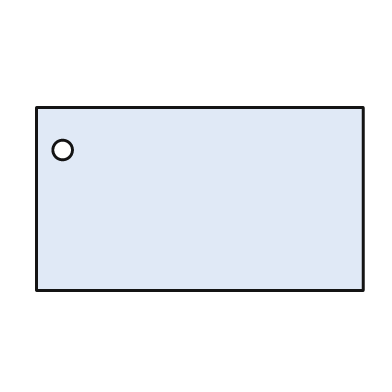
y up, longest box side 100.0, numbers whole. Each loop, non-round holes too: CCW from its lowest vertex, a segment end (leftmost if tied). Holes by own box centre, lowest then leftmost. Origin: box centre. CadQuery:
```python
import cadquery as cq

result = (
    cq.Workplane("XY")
    .moveTo(-50.0, -28.0)
    .lineTo(50.0, -28.0)
    .lineTo(50.0, 28.0)
    .lineTo(-50.0, 28.0)
    .close()
    .moveTo(-42.0, 15.0)
    .circle(3.0)
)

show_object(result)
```